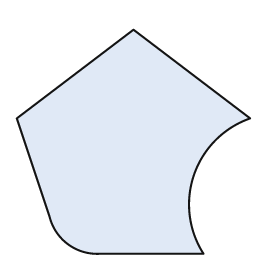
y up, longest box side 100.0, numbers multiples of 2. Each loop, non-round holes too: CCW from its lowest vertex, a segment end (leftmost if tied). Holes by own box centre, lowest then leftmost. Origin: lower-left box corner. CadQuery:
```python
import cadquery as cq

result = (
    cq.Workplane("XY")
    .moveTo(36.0, 0.0)
    .lineTo(80.0, 0.0)
    .threePointArc((76.0, 34.0), (100.0, 58.0))
    .lineTo(50.0, 96.0)
    .lineTo(0.0, 58.0)
    .lineTo(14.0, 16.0)
    .threePointArc((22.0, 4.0), (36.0, 0.0))
    .close()
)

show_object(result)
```